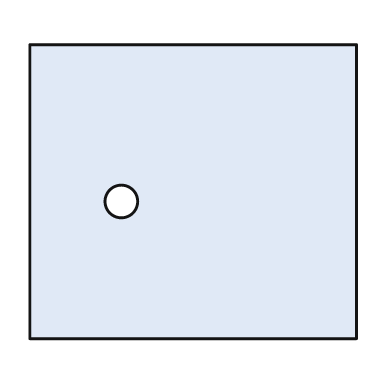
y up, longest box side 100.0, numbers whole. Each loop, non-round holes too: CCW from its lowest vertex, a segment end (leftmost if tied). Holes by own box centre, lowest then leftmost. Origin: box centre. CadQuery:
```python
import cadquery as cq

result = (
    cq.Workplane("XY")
    .moveTo(-50.0, -45.0)
    .lineTo(50.0, -45.0)
    .lineTo(50.0, 45.0)
    .lineTo(-50.0, 45.0)
    .close()
    .moveTo(-22.0, -3.0)
    .circle(5.0)
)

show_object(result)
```